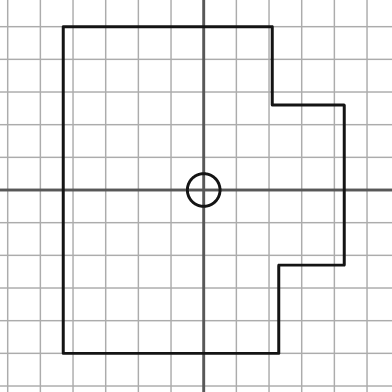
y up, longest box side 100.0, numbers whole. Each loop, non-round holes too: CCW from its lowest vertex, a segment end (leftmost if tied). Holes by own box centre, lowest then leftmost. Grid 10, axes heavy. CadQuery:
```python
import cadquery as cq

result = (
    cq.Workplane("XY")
    .moveTo(-43.0, -50.0)
    .lineTo(23.0, -50.0)
    .lineTo(23.0, -23.0)
    .lineTo(43.0, -23.0)
    .lineTo(43.0, 26.0)
    .lineTo(21.0, 26.0)
    .lineTo(21.0, 50.0)
    .lineTo(-43.0, 50.0)
    .close()
    .moveTo(0.0, 0.0)
    .circle(5.0)
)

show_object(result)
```